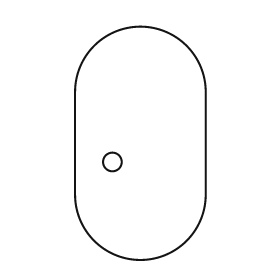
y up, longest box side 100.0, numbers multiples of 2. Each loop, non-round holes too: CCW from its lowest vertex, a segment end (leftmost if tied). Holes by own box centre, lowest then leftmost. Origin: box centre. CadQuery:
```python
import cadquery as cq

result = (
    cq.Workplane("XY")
    .moveTo(-28.0, -22.0)
    .threePointArc((0.0, -50.0), (28.0, -22.0))
    .lineTo(28.0, 22.0)
    .threePointArc((0.0, 50.0), (-28.0, 22.0))
    .close()
    .moveTo(-12.0, -8.0)
    .circle(4.0)
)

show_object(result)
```